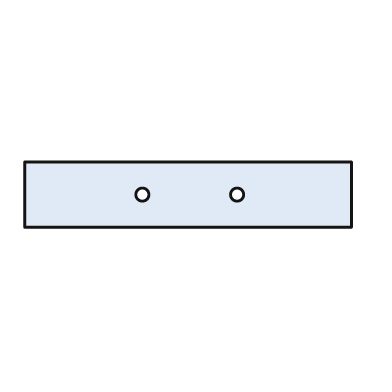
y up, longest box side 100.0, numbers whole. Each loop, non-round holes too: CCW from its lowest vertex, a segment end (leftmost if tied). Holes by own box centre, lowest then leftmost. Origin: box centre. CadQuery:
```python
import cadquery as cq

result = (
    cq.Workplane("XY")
    .moveTo(-50.0, -10.0)
    .lineTo(50.0, -10.0)
    .lineTo(50.0, 10.0)
    .lineTo(-50.0, 10.0)
    .close()
    .moveTo(-14.0, 0.0)
    .circle(2.0)
    .moveTo(15.0, 0.0)
    .circle(2.0)
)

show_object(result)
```